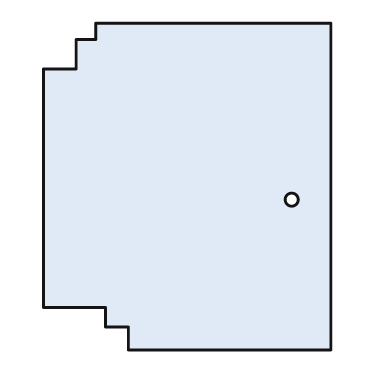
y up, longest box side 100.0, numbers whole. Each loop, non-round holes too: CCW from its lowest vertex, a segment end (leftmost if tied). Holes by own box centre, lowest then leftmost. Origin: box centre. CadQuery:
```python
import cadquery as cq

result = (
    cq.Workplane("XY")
    .moveTo(-18.0, -50.0)
    .lineTo(44.0, -50.0)
    .lineTo(44.0, 50.0)
    .lineTo(-28.0, 50.0)
    .lineTo(-28.0, 45.0)
    .lineTo(-34.0, 45.0)
    .lineTo(-34.0, 36.0)
    .lineTo(-44.0, 36.0)
    .lineTo(-44.0, -37.0)
    .lineTo(-25.0, -37.0)
    .lineTo(-25.0, -43.0)
    .lineTo(-18.0, -43.0)
    .close()
    .moveTo(32.0, -4.0)
    .circle(2.0)
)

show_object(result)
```